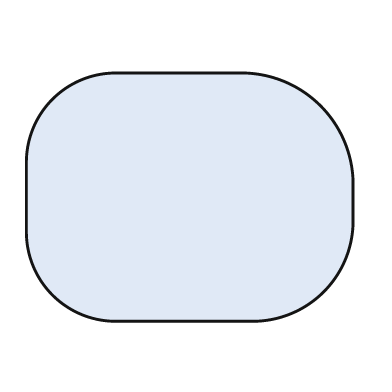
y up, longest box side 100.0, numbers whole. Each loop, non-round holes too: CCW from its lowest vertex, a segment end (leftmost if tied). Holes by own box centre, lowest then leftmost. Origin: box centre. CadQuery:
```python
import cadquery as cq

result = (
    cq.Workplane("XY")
    .moveTo(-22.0, -38.0)
    .lineTo(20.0, -38.0)
    .threePointArc((41.0, -29.0), (50.0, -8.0))
    .lineTo(50.0, 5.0)
    .threePointArc((40.0, 28.0), (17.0, 38.0))
    .lineTo(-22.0, 38.0)
    .threePointArc((-42.0, 30.0), (-50.0, 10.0))
    .lineTo(-50.0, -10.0)
    .threePointArc((-42.0, -30.0), (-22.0, -38.0))
    .close()
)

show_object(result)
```